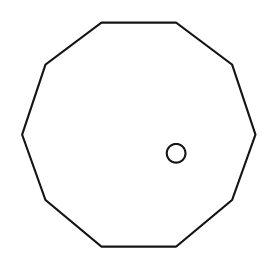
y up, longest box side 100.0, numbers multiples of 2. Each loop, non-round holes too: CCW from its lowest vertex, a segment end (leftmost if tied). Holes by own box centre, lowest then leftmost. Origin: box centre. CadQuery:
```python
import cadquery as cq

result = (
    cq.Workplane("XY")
    .moveTo(-16.0, -48.0)
    .lineTo(16.0, -48.0)
    .lineTo(40.0, -28.0)
    .lineTo(50.0, 0.0)
    .lineTo(40.0, 30.0)
    .lineTo(16.0, 48.0)
    .lineTo(-16.0, 48.0)
    .lineTo(-40.0, 30.0)
    .lineTo(-50.0, 0.0)
    .lineTo(-40.0, -28.0)
    .close()
    .moveTo(16.0, -8.0)
    .circle(4.0)
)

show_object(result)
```